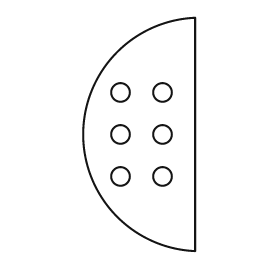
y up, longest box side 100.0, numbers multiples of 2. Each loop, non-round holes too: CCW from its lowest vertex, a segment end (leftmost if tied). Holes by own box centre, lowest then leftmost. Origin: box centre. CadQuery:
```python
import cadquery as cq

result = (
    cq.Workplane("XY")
    .moveTo(24.0, -50.0)
    .lineTo(24.0, 50.0)
    .threePointArc((-24.0, 0.0), (24.0, -50.0))
    .close()
    .moveTo(-8.0, -18.0)
    .circle(4.0)
    .moveTo(10.0, -18.0)
    .circle(4.0)
    .moveTo(-8.0, 0.0)
    .circle(4.0)
    .moveTo(10.0, 0.0)
    .circle(4.0)
    .moveTo(-8.0, 18.0)
    .circle(4.0)
    .moveTo(10.0, 18.0)
    .circle(4.0)
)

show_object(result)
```